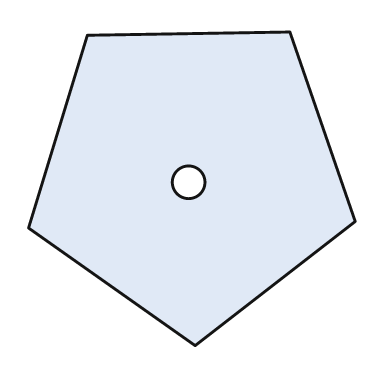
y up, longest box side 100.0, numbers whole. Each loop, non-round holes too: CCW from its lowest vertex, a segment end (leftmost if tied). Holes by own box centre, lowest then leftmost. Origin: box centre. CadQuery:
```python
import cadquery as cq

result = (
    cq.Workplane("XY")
    .moveTo(1.0, -48.0)
    .lineTo(50.0, -10.0)
    .lineTo(30.0, 48.0)
    .lineTo(-32.0, 47.0)
    .lineTo(-50.0, -12.0)
    .close()
    .moveTo(-1.0, 2.0)
    .circle(5.0)
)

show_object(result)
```